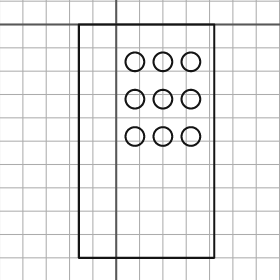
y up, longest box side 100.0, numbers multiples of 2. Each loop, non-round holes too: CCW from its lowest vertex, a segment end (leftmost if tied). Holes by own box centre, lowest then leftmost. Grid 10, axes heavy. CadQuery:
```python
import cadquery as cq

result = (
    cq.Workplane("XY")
    .moveTo(-16.0, -100.0)
    .lineTo(42.0, -100.0)
    .lineTo(42.0, 0.0)
    .lineTo(-16.0, 0.0)
    .close()
    .moveTo(8.0, -48.0)
    .circle(4.0)
    .moveTo(20.0, -48.0)
    .circle(4.0)
    .moveTo(32.0, -48.0)
    .circle(4.0)
    .moveTo(8.0, -32.0)
    .circle(4.0)
    .moveTo(20.0, -32.0)
    .circle(4.0)
    .moveTo(32.0, -32.0)
    .circle(4.0)
    .moveTo(8.0, -16.0)
    .circle(4.0)
    .moveTo(20.0, -16.0)
    .circle(4.0)
    .moveTo(32.0, -16.0)
    .circle(4.0)
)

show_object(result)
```